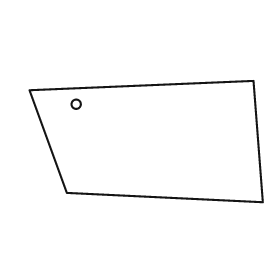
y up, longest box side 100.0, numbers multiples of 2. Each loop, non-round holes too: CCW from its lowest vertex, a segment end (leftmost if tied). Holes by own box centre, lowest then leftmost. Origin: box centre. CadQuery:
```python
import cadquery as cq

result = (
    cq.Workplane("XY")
    .moveTo(50.0, -26.0)
    .lineTo(46.0, 26.0)
    .lineTo(-50.0, 22.0)
    .lineTo(-34.0, -22.0)
    .close()
    .moveTo(-30.0, 16.0)
    .circle(2.0)
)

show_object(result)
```